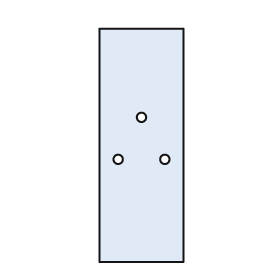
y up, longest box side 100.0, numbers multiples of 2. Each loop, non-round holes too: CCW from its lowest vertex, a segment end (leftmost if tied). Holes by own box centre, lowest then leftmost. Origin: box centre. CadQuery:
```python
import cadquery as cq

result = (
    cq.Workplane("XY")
    .moveTo(-18.0, -50.0)
    .lineTo(18.0, -50.0)
    .lineTo(18.0, 50.0)
    .lineTo(-18.0, 50.0)
    .close()
    .moveTo(-10.0, -6.0)
    .circle(2.0)
    .moveTo(10.0, -6.0)
    .circle(2.0)
    .moveTo(0.0, 12.0)
    .circle(2.0)
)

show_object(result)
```